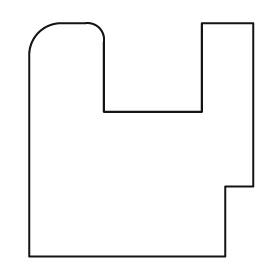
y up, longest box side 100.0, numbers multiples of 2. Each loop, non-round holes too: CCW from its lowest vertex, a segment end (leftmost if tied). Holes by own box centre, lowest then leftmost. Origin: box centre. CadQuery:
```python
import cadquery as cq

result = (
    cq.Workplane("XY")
    .moveTo(-48.0, -50.0)
    .lineTo(36.0, -50.0)
    .lineTo(36.0, -20.0)
    .lineTo(48.0, -20.0)
    .lineTo(48.0, 50.0)
    .lineTo(26.0, 50.0)
    .lineTo(26.0, 12.0)
    .lineTo(-16.0, 12.0)
    .lineTo(-16.0, 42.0)
    .threePointArc((-18.0, 48.0), (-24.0, 50.0))
    .lineTo(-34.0, 50.0)
    .threePointArc((-44.0, 46.0), (-48.0, 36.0))
    .close()
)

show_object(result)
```